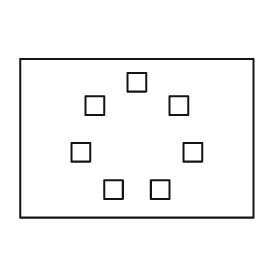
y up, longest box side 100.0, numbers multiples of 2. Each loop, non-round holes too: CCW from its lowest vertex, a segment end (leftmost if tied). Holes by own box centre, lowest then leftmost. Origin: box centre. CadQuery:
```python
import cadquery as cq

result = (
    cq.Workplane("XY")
    .moveTo(-50.0, -34.0)
    .lineTo(50.0, -34.0)
    .lineTo(50.0, 34.0)
    .lineTo(-50.0, 34.0)
    .close()
    .moveTo(-14.0, -26.0)
    .lineTo(-6.0, -26.0)
    .lineTo(-6.0, -18.0)
    .lineTo(-14.0, -18.0)
    .close()
    .moveTo(6.0, -26.0)
    .lineTo(14.0, -26.0)
    .lineTo(14.0, -18.0)
    .lineTo(6.0, -18.0)
    .close()
    .moveTo(-28.0, -10.0)
    .lineTo(-20.0, -10.0)
    .lineTo(-20.0, -2.0)
    .lineTo(-28.0, -2.0)
    .close()
    .moveTo(20.0, -10.0)
    .lineTo(28.0, -10.0)
    .lineTo(28.0, -2.0)
    .lineTo(20.0, -2.0)
    .close()
    .moveTo(-22.0, 10.0)
    .lineTo(-14.0, 10.0)
    .lineTo(-14.0, 18.0)
    .lineTo(-22.0, 18.0)
    .close()
    .moveTo(14.0, 10.0)
    .lineTo(22.0, 10.0)
    .lineTo(22.0, 18.0)
    .lineTo(14.0, 18.0)
    .close()
    .moveTo(-4.0, 20.0)
    .lineTo(4.0, 20.0)
    .lineTo(4.0, 28.0)
    .lineTo(-4.0, 28.0)
    .close()
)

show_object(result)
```